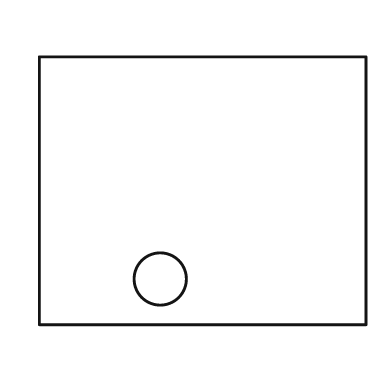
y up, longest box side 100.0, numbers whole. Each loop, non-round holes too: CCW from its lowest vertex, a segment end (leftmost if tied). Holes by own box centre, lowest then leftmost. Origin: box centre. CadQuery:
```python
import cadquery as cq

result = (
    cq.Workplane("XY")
    .moveTo(-50.0, -41.0)
    .lineTo(50.0, -41.0)
    .lineTo(50.0, 41.0)
    .lineTo(-50.0, 41.0)
    .close()
    .moveTo(-13.0, -27.0)
    .circle(8.0)
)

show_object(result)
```